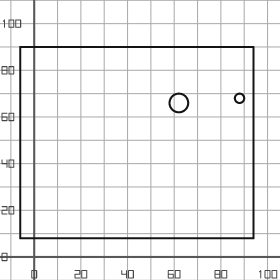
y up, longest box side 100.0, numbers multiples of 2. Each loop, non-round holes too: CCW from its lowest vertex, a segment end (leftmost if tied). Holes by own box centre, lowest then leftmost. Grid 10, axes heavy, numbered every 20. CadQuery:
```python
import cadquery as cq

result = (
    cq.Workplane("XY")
    .moveTo(-6.0, 8.0)
    .lineTo(94.0, 8.0)
    .lineTo(94.0, 90.0)
    .lineTo(-6.0, 90.0)
    .close()
    .moveTo(62.0, 66.0)
    .circle(4.0)
    .moveTo(88.0, 68.0)
    .circle(2.0)
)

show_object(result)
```